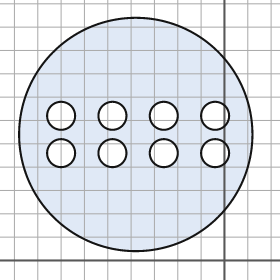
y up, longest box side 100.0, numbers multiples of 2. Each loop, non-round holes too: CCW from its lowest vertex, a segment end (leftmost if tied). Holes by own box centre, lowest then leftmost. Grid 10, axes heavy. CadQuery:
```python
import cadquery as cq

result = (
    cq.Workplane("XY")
    .moveTo(-38.0, 54.0)
    .circle(50.0)
    .moveTo(-70.0, 46.0)
    .circle(6.0)
    .moveTo(-48.0, 46.0)
    .circle(6.0)
    .moveTo(-26.0, 46.0)
    .circle(6.0)
    .moveTo(-4.0, 46.0)
    .circle(6.0)
    .moveTo(-70.0, 62.0)
    .circle(6.0)
    .moveTo(-48.0, 62.0)
    .circle(6.0)
    .moveTo(-26.0, 62.0)
    .circle(6.0)
    .moveTo(-4.0, 62.0)
    .circle(6.0)
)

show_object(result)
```